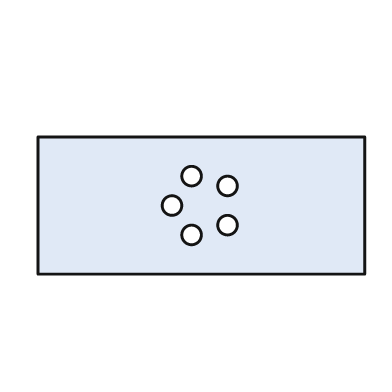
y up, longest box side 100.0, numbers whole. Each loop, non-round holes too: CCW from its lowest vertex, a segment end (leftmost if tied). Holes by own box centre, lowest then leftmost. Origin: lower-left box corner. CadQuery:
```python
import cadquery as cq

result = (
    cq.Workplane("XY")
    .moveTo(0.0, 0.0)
    .lineTo(100.0, 0.0)
    .lineTo(100.0, 42.0)
    .lineTo(0.0, 42.0)
    .close()
    .moveTo(47.0, 12.0)
    .circle(3.0)
    .moveTo(58.0, 15.0)
    .circle(3.0)
    .moveTo(41.0, 21.0)
    .circle(3.0)
    .moveTo(58.0, 27.0)
    .circle(3.0)
    .moveTo(47.0, 30.0)
    .circle(3.0)
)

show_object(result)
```